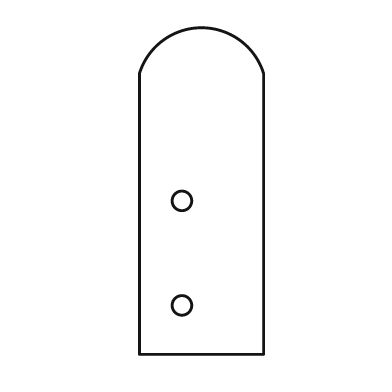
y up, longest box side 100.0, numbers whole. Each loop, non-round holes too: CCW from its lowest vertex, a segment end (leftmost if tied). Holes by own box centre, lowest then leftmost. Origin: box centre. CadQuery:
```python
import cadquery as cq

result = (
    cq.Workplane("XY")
    .moveTo(-19.0, -50.0)
    .lineTo(19.0, -50.0)
    .lineTo(19.0, 36.0)
    .threePointArc((0.0, 50.0), (-19.0, 36.0))
    .close()
    .moveTo(-6.0, -35.0)
    .circle(3.0)
    .moveTo(-6.0, -3.0)
    .circle(3.0)
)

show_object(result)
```